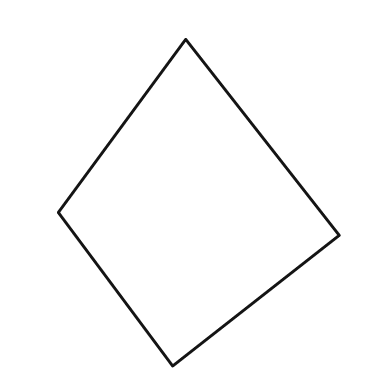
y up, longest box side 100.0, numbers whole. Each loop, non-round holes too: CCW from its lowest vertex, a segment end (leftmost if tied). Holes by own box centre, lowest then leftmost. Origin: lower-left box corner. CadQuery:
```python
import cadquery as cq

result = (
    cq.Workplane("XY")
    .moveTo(35.0, 0.0)
    .lineTo(86.0, 40.0)
    .lineTo(39.0, 100.0)
    .lineTo(0.0, 47.0)
    .close()
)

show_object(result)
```